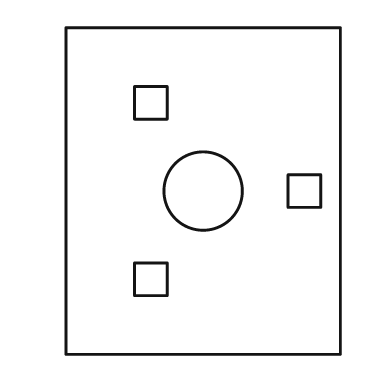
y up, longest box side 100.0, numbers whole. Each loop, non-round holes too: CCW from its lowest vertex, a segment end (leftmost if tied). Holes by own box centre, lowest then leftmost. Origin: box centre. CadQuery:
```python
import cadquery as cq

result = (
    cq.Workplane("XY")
    .moveTo(-42.0, -50.0)
    .lineTo(42.0, -50.0)
    .lineTo(42.0, 50.0)
    .lineTo(-42.0, 50.0)
    .close()
    .moveTo(-21.0, -32.0)
    .lineTo(-11.0, -32.0)
    .lineTo(-11.0, -22.0)
    .lineTo(-21.0, -22.0)
    .close()
    .moveTo(0.0, 0.0)
    .circle(12.0)
    .moveTo(26.0, -5.0)
    .lineTo(36.0, -5.0)
    .lineTo(36.0, 5.0)
    .lineTo(26.0, 5.0)
    .close()
    .moveTo(-21.0, 22.0)
    .lineTo(-11.0, 22.0)
    .lineTo(-11.0, 32.0)
    .lineTo(-21.0, 32.0)
    .close()
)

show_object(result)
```